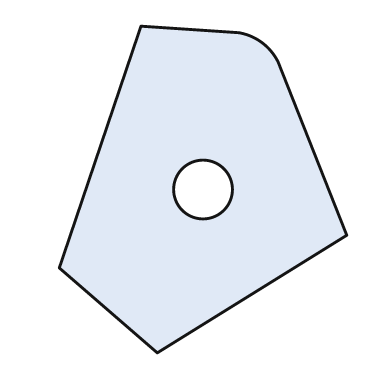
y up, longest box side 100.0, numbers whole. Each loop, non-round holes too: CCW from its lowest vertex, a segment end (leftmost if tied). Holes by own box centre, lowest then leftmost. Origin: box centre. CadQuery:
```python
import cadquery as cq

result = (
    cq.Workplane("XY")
    .moveTo(-14.0, -50.0)
    .lineTo(44.0, -14.0)
    .lineTo(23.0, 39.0)
    .threePointArc((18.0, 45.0), (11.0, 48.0))
    .lineTo(-19.0, 50.0)
    .lineTo(-44.0, -24.0)
    .close()
    .moveTo(0.0, 0.0)
    .circle(9.0)
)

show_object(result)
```